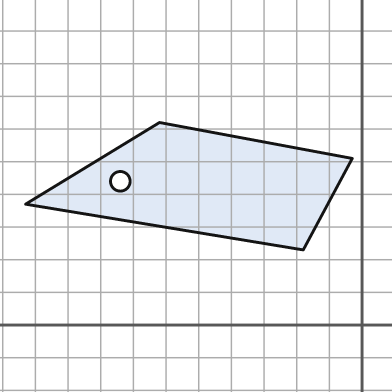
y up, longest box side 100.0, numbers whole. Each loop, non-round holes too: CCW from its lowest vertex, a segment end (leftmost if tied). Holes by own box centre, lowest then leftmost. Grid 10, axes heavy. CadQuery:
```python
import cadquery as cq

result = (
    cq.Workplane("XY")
    .moveTo(-18.0, 23.0)
    .lineTo(-3.0, 51.0)
    .lineTo(-62.0, 62.0)
    .lineTo(-103.0, 37.0)
    .close()
    .moveTo(-74.0, 44.0)
    .circle(3.0)
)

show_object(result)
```